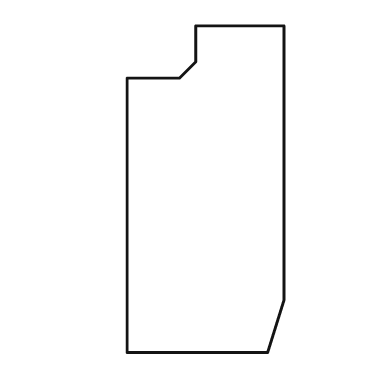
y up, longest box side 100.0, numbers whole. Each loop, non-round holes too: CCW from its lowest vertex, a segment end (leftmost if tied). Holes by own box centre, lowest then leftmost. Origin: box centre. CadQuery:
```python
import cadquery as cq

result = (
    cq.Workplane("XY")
    .moveTo(-24.0, -50.0)
    .lineTo(19.0, -50.0)
    .lineTo(24.0, -34.0)
    .lineTo(24.0, 50.0)
    .lineTo(-3.0, 50.0)
    .lineTo(-3.0, 39.0)
    .lineTo(-8.0, 34.0)
    .lineTo(-24.0, 34.0)
    .close()
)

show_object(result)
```